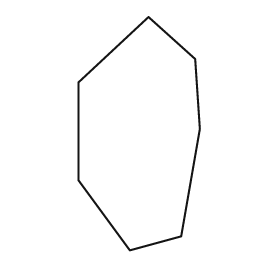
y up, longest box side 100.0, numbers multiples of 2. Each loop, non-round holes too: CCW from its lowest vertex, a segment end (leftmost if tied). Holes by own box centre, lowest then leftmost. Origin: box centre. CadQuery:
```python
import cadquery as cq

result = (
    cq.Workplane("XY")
    .moveTo(-4.0, -50.0)
    .lineTo(18.0, -44.0)
    .lineTo(26.0, 2.0)
    .lineTo(24.0, 32.0)
    .lineTo(4.0, 50.0)
    .lineTo(-26.0, 22.0)
    .lineTo(-26.0, -20.0)
    .close()
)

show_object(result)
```